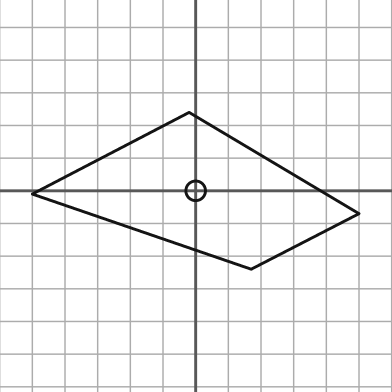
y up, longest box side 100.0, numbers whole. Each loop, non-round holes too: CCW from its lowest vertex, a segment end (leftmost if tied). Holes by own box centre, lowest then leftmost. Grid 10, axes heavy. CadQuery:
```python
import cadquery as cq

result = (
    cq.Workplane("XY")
    .moveTo(17.0, -24.0)
    .lineTo(50.0, -7.0)
    .lineTo(-2.0, 24.0)
    .lineTo(-50.0, -1.0)
    .close()
    .moveTo(0.0, 0.0)
    .circle(3.0)
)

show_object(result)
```